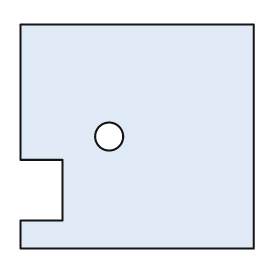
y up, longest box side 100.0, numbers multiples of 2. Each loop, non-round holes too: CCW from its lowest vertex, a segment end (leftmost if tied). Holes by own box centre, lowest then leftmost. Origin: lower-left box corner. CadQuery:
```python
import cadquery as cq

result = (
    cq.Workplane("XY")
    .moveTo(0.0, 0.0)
    .lineTo(100.0, 0.0)
    .lineTo(100.0, 96.0)
    .lineTo(0.0, 96.0)
    .lineTo(0.0, 38.0)
    .lineTo(18.0, 38.0)
    .lineTo(18.0, 12.0)
    .lineTo(0.0, 12.0)
    .close()
    .moveTo(38.0, 48.0)
    .circle(6.0)
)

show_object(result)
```